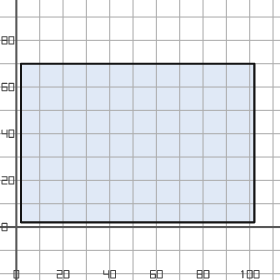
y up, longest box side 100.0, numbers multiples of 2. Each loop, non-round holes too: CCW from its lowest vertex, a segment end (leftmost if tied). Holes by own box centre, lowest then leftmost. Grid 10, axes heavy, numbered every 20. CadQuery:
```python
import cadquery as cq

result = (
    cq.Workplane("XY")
    .moveTo(2.0, 2.0)
    .lineTo(102.0, 2.0)
    .lineTo(102.0, 70.0)
    .lineTo(2.0, 70.0)
    .close()
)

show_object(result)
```